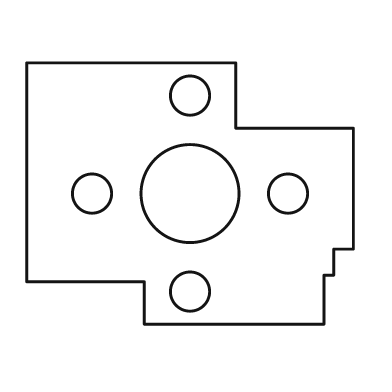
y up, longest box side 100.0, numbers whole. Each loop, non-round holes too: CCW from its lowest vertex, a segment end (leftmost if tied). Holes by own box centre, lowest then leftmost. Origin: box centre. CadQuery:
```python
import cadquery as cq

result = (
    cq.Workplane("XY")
    .moveTo(-14.0, -40.0)
    .lineTo(41.0, -40.0)
    .lineTo(41.0, -25.0)
    .lineTo(44.0, -25.0)
    .lineTo(44.0, -17.0)
    .lineTo(50.0, -17.0)
    .lineTo(50.0, 20.0)
    .lineTo(14.0, 20.0)
    .lineTo(14.0, 40.0)
    .lineTo(-50.0, 40.0)
    .lineTo(-50.0, -27.0)
    .lineTo(-14.0, -27.0)
    .close()
    .moveTo(0.0, -30.0)
    .circle(6.0)
    .moveTo(-30.0, 0.0)
    .circle(6.0)
    .moveTo(0.0, 0.0)
    .circle(15.0)
    .moveTo(30.0, 0.0)
    .circle(6.0)
    .moveTo(0.0, 30.0)
    .circle(6.0)
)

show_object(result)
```